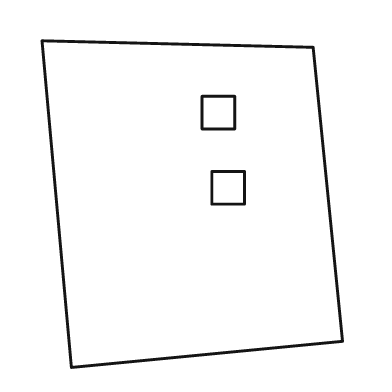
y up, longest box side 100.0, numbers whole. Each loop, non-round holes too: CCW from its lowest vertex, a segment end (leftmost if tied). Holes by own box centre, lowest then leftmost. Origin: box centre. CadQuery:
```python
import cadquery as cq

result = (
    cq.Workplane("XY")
    .moveTo(-37.0, -50.0)
    .lineTo(46.0, -42.0)
    .lineTo(37.0, 48.0)
    .lineTo(-46.0, 50.0)
    .close()
    .moveTo(6.0, 0.0)
    .lineTo(16.0, 0.0)
    .lineTo(16.0, 10.0)
    .lineTo(6.0, 10.0)
    .close()
    .moveTo(3.0, 23.0)
    .lineTo(13.0, 23.0)
    .lineTo(13.0, 33.0)
    .lineTo(3.0, 33.0)
    .close()
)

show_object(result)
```